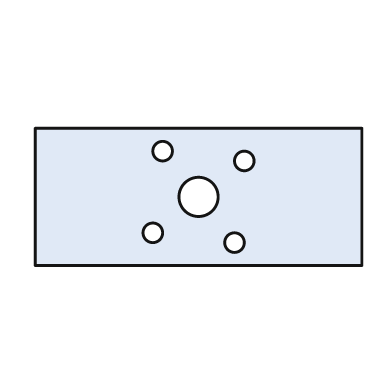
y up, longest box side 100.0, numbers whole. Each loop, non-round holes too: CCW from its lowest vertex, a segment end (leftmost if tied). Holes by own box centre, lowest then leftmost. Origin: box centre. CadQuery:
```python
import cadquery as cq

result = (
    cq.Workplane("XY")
    .moveTo(-50.0, -21.0)
    .lineTo(50.0, -21.0)
    .lineTo(50.0, 21.0)
    .lineTo(-50.0, 21.0)
    .close()
    .moveTo(11.0, -14.0)
    .circle(3.0)
    .moveTo(-14.0, -11.0)
    .circle(3.0)
    .moveTo(0.0, 0.0)
    .circle(6.0)
    .moveTo(14.0, 11.0)
    .circle(3.0)
    .moveTo(-11.0, 14.0)
    .circle(3.0)
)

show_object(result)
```